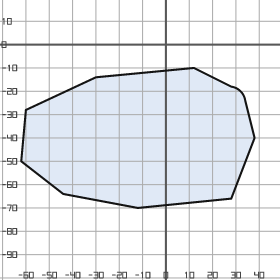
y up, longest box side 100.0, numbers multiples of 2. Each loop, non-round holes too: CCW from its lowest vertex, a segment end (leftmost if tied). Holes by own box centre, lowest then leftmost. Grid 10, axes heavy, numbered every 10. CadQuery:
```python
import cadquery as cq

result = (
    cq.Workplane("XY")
    .moveTo(-12.0, -70.0)
    .lineTo(28.0, -66.0)
    .lineTo(38.0, -40.0)
    .lineTo(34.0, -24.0)
    .threePointArc((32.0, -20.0), (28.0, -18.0))
    .lineTo(12.0, -10.0)
    .lineTo(-30.0, -14.0)
    .lineTo(-60.0, -28.0)
    .lineTo(-62.0, -50.0)
    .lineTo(-44.0, -64.0)
    .close()
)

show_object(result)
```